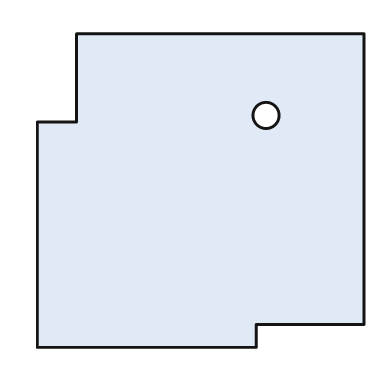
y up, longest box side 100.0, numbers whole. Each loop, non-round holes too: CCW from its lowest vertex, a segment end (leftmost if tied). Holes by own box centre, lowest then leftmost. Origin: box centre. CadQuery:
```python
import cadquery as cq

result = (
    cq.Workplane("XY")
    .moveTo(-50.0, -48.0)
    .lineTo(17.0, -48.0)
    .lineTo(17.0, -41.0)
    .lineTo(50.0, -41.0)
    .lineTo(50.0, 48.0)
    .lineTo(-38.0, 48.0)
    .lineTo(-38.0, 21.0)
    .lineTo(-50.0, 21.0)
    .close()
    .moveTo(20.0, 23.0)
    .circle(4.0)
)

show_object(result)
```